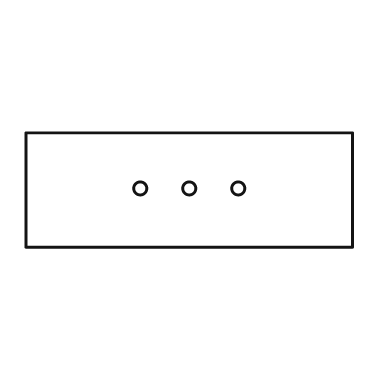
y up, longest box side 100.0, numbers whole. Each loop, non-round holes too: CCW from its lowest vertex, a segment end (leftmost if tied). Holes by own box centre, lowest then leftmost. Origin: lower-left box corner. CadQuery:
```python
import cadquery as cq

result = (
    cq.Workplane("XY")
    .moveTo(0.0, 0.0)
    .lineTo(100.0, 0.0)
    .lineTo(100.0, 35.0)
    .lineTo(0.0, 35.0)
    .close()
    .moveTo(35.0, 18.0)
    .circle(2.0)
    .moveTo(50.0, 18.0)
    .circle(2.0)
    .moveTo(65.0, 18.0)
    .circle(2.0)
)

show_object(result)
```